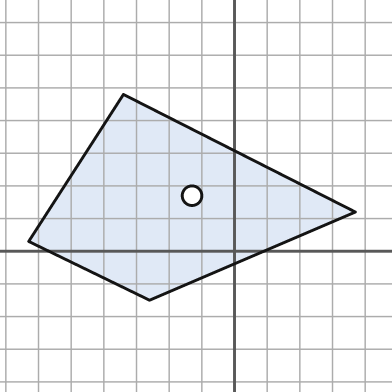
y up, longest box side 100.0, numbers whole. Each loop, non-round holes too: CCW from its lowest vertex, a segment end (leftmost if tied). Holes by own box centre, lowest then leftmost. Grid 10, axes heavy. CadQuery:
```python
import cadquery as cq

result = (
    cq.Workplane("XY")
    .moveTo(-26.0, -15.0)
    .lineTo(37.0, 12.0)
    .lineTo(-34.0, 48.0)
    .lineTo(-63.0, 3.0)
    .close()
    .moveTo(-13.0, 17.0)
    .circle(3.0)
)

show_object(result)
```